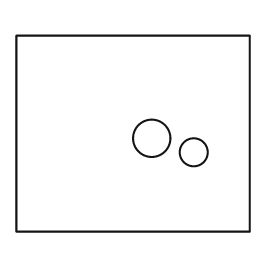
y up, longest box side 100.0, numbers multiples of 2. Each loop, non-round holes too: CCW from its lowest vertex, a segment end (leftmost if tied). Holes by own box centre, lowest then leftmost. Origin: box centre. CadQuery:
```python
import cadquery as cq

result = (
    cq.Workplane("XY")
    .moveTo(-50.0, -42.0)
    .lineTo(50.0, -42.0)
    .lineTo(50.0, 42.0)
    .lineTo(-50.0, 42.0)
    .close()
    .moveTo(26.0, -8.0)
    .circle(6.0)
    .moveTo(8.0, -2.0)
    .circle(8.0)
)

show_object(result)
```